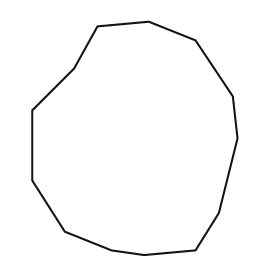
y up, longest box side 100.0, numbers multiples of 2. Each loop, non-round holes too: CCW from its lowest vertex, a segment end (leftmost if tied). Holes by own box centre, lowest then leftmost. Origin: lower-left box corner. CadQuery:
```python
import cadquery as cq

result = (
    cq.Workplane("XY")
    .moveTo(48.0, 0.0)
    .lineTo(70.0, 2.0)
    .lineTo(80.0, 18.0)
    .lineTo(88.0, 50.0)
    .lineTo(86.0, 68.0)
    .lineTo(70.0, 92.0)
    .lineTo(50.0, 100.0)
    .lineTo(28.0, 98.0)
    .lineTo(18.0, 80.0)
    .lineTo(0.0, 62.0)
    .lineTo(0.0, 32.0)
    .lineTo(14.0, 10.0)
    .lineTo(34.0, 2.0)
    .close()
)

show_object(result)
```